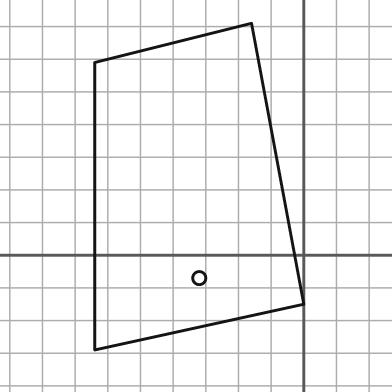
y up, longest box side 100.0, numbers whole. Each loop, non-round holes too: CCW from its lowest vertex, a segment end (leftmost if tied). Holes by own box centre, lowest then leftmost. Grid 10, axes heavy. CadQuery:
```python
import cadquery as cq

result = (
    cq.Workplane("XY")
    .moveTo(-64.0, -29.0)
    .lineTo(0.0, -15.0)
    .lineTo(-16.0, 71.0)
    .lineTo(-64.0, 59.0)
    .close()
    .moveTo(-32.0, -7.0)
    .circle(2.0)
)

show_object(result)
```